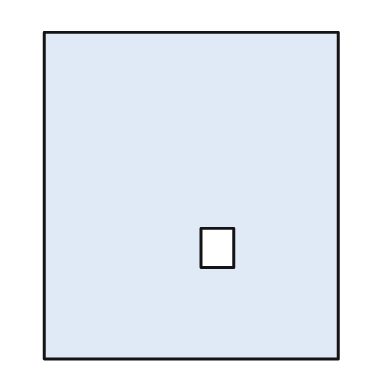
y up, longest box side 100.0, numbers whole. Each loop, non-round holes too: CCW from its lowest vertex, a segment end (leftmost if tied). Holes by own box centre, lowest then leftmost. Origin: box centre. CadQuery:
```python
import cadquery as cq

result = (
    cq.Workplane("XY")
    .moveTo(-45.0, -50.0)
    .lineTo(45.0, -50.0)
    .lineTo(45.0, 50.0)
    .lineTo(-45.0, 50.0)
    .close()
    .moveTo(3.0, -22.0)
    .lineTo(13.0, -22.0)
    .lineTo(13.0, -10.0)
    .lineTo(3.0, -10.0)
    .close()
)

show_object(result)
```